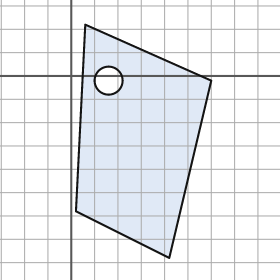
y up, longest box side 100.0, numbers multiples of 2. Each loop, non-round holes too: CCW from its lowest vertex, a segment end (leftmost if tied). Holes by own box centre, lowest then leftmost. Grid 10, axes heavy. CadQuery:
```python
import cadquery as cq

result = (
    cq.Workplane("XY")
    .moveTo(42.0, -78.0)
    .lineTo(60.0, -2.0)
    .lineTo(6.0, 22.0)
    .lineTo(2.0, -58.0)
    .close()
    .moveTo(16.0, -2.0)
    .circle(6.0)
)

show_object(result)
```